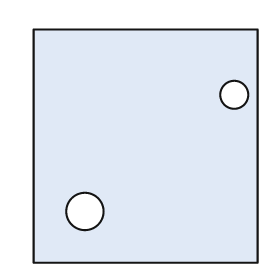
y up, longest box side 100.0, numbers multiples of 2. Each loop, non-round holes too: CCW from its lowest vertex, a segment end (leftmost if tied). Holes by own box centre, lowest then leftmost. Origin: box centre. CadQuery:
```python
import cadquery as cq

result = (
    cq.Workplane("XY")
    .moveTo(-48.0, -50.0)
    .lineTo(48.0, -50.0)
    .lineTo(48.0, 50.0)
    .lineTo(-48.0, 50.0)
    .close()
    .moveTo(-26.0, -28.0)
    .circle(8.0)
    .moveTo(38.0, 22.0)
    .circle(6.0)
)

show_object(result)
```